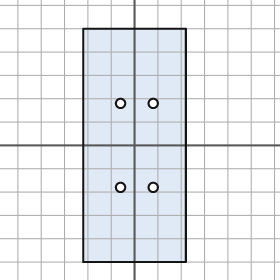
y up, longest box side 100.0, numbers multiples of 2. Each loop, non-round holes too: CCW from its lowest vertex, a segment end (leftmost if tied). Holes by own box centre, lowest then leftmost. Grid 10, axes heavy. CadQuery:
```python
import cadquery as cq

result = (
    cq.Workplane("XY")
    .moveTo(-22.0, -50.0)
    .lineTo(22.0, -50.0)
    .lineTo(22.0, 50.0)
    .lineTo(-22.0, 50.0)
    .close()
    .moveTo(-6.0, -18.0)
    .circle(2.0)
    .moveTo(8.0, -18.0)
    .circle(2.0)
    .moveTo(-6.0, 18.0)
    .circle(2.0)
    .moveTo(8.0, 18.0)
    .circle(2.0)
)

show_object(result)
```